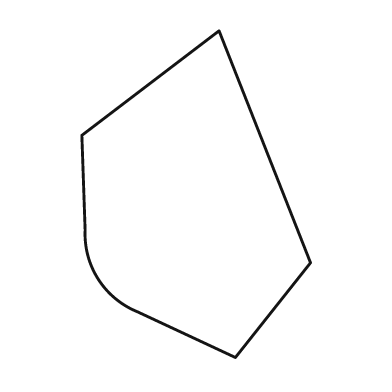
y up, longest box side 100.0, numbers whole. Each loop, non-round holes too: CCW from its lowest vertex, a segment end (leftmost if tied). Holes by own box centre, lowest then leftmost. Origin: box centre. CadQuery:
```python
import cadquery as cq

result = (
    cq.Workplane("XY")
    .moveTo(12.0, -50.0)
    .lineTo(35.0, -21.0)
    .lineTo(7.0, 50.0)
    .lineTo(-35.0, 18.0)
    .lineTo(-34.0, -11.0)
    .threePointArc((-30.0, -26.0), (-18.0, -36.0))
    .close()
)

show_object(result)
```